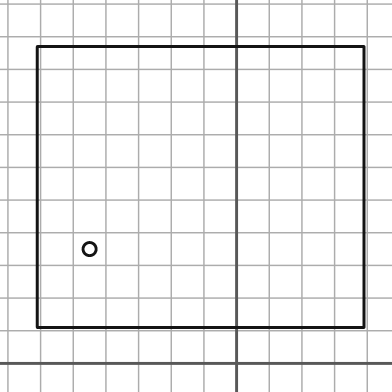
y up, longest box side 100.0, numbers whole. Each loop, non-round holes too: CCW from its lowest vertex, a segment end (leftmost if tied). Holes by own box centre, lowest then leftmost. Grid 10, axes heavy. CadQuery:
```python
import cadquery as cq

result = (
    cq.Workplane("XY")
    .moveTo(-61.0, 11.0)
    .lineTo(39.0, 11.0)
    .lineTo(39.0, 97.0)
    .lineTo(-61.0, 97.0)
    .close()
    .moveTo(-45.0, 35.0)
    .circle(2.0)
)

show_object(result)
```